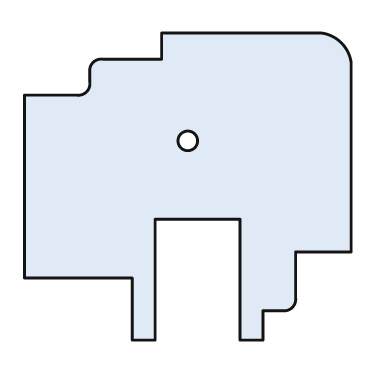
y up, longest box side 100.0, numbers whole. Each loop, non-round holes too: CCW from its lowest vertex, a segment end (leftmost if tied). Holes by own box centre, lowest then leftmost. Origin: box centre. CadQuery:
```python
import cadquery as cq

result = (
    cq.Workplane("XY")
    .moveTo(-17.0, -47.0)
    .lineTo(-10.0, -47.0)
    .lineTo(-10.0, -10.0)
    .lineTo(16.0, -10.0)
    .lineTo(16.0, -47.0)
    .lineTo(23.0, -47.0)
    .lineTo(23.0, -38.0)
    .lineTo(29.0, -38.0)
    .threePointArc((32.0, -37.0), (33.0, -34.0))
    .lineTo(33.0, -20.0)
    .lineTo(50.0, -20.0)
    .lineTo(50.0, 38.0)
    .threePointArc((47.0, 44.0), (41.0, 47.0))
    .lineTo(-8.0, 47.0)
    .lineTo(-8.0, 39.0)
    .lineTo(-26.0, 39.0)
    .threePointArc((-29.0, 38.0), (-30.0, 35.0))
    .lineTo(-30.0, 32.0)
    .threePointArc((-31.0, 29.0), (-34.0, 28.0))
    .lineTo(-50.0, 28.0)
    .lineTo(-50.0, -28.0)
    .lineTo(-17.0, -28.0)
    .close()
    .moveTo(0.0, 14.0)
    .circle(3.0)
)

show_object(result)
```